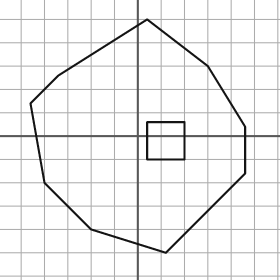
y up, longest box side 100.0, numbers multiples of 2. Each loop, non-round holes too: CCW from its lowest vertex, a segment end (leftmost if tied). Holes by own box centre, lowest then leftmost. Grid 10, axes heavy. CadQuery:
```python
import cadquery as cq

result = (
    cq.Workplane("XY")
    .moveTo(12.0, -50.0)
    .lineTo(46.0, -16.0)
    .lineTo(46.0, 4.0)
    .lineTo(30.0, 30.0)
    .lineTo(4.0, 50.0)
    .lineTo(-34.0, 26.0)
    .lineTo(-46.0, 14.0)
    .lineTo(-40.0, -20.0)
    .lineTo(-20.0, -40.0)
    .close()
    .moveTo(4.0, -10.0)
    .lineTo(20.0, -10.0)
    .lineTo(20.0, 6.0)
    .lineTo(4.0, 6.0)
    .close()
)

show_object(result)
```